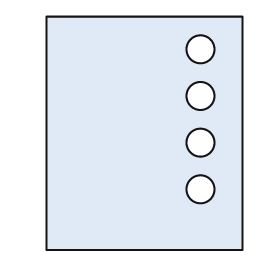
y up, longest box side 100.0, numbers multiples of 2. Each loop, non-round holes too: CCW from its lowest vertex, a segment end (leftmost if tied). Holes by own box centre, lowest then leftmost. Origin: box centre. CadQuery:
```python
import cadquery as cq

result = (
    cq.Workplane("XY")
    .moveTo(-42.0, -50.0)
    .lineTo(42.0, -50.0)
    .lineTo(42.0, 50.0)
    .lineTo(-42.0, 50.0)
    .close()
    .moveTo(24.0, -24.0)
    .circle(6.0)
    .moveTo(24.0, -4.0)
    .circle(6.0)
    .moveTo(24.0, 16.0)
    .circle(6.0)
    .moveTo(24.0, 36.0)
    .circle(6.0)
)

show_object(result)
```